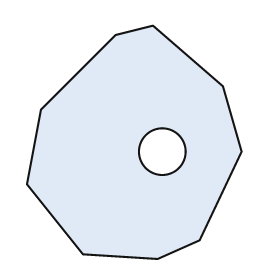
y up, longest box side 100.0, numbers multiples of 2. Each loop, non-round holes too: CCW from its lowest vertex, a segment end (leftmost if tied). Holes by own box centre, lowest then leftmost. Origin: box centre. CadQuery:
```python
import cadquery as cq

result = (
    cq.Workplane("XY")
    .moveTo(10.0, -50.0)
    .lineTo(28.0, -42.0)
    .lineTo(46.0, -4.0)
    .lineTo(38.0, 24.0)
    .lineTo(8.0, 50.0)
    .lineTo(-8.0, 46.0)
    .lineTo(-40.0, 14.0)
    .lineTo(-46.0, -18.0)
    .lineTo(-22.0, -48.0)
    .close()
    .moveTo(12.0, -4.0)
    .circle(10.0)
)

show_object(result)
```